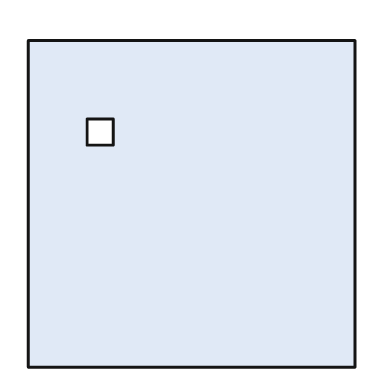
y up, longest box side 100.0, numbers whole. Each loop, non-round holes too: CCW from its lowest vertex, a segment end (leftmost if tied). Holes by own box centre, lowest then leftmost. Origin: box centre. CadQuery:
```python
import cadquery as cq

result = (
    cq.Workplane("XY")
    .moveTo(-50.0, -50.0)
    .lineTo(50.0, -50.0)
    .lineTo(50.0, 50.0)
    .lineTo(-50.0, 50.0)
    .close()
    .moveTo(-32.0, 18.0)
    .lineTo(-24.0, 18.0)
    .lineTo(-24.0, 26.0)
    .lineTo(-32.0, 26.0)
    .close()
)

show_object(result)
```